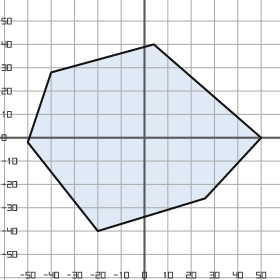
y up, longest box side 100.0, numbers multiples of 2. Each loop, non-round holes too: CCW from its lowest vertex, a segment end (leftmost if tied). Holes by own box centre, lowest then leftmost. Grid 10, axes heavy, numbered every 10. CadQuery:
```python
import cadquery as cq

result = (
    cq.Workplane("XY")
    .moveTo(-20.0, -40.0)
    .lineTo(26.0, -26.0)
    .lineTo(50.0, 0.0)
    .lineTo(4.0, 40.0)
    .lineTo(-40.0, 28.0)
    .lineTo(-50.0, -2.0)
    .close()
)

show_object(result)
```